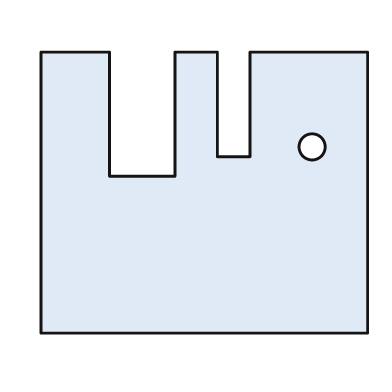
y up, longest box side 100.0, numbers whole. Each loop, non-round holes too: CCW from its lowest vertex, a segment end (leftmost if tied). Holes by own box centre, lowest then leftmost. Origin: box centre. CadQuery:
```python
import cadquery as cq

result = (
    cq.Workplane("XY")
    .moveTo(-50.0, -43.0)
    .lineTo(50.0, -43.0)
    .lineTo(50.0, 43.0)
    .lineTo(14.0, 43.0)
    .lineTo(14.0, 11.0)
    .lineTo(4.0, 11.0)
    .lineTo(4.0, 43.0)
    .lineTo(-9.0, 43.0)
    .lineTo(-9.0, 5.0)
    .lineTo(-29.0, 5.0)
    .lineTo(-29.0, 43.0)
    .lineTo(-50.0, 43.0)
    .close()
    .moveTo(33.0, 14.0)
    .circle(4.0)
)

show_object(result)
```